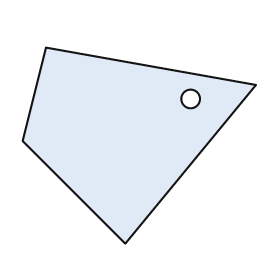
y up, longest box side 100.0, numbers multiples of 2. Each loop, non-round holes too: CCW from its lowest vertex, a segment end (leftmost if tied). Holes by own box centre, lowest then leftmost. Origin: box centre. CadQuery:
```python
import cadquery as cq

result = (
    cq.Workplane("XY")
    .moveTo(-6.0, -42.0)
    .lineTo(50.0, 26.0)
    .lineTo(-40.0, 42.0)
    .lineTo(-50.0, 2.0)
    .close()
    .moveTo(22.0, 20.0)
    .circle(4.0)
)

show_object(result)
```